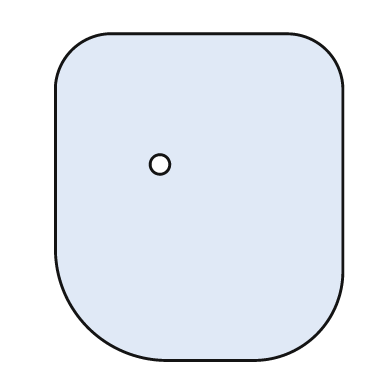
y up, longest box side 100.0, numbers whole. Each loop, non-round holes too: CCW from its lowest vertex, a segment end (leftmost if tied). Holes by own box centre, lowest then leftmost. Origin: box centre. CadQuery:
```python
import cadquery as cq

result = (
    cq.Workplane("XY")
    .moveTo(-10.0, -50.0)
    .lineTo(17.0, -50.0)
    .threePointArc((36.0, -42.0), (44.0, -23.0))
    .lineTo(44.0, 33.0)
    .threePointArc((39.0, 45.0), (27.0, 50.0))
    .lineTo(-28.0, 50.0)
    .threePointArc((-39.0, 45.0), (-44.0, 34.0))
    .lineTo(-44.0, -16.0)
    .threePointArc((-34.0, -40.0), (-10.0, -50.0))
    .close()
    .moveTo(-12.0, 10.0)
    .circle(3.0)
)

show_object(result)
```